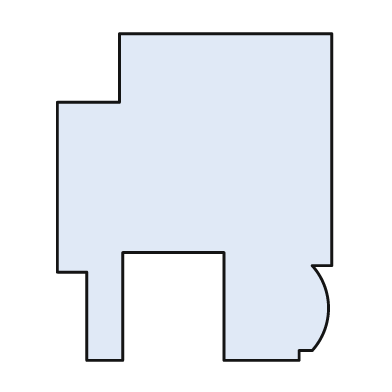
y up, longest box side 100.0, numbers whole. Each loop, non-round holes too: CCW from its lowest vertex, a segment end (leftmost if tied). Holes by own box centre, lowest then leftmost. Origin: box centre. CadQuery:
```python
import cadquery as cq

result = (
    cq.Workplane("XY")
    .moveTo(-33.0, -50.0)
    .lineTo(-22.0, -50.0)
    .lineTo(-22.0, -17.0)
    .lineTo(9.0, -17.0)
    .lineTo(9.0, -50.0)
    .lineTo(32.0, -50.0)
    .lineTo(32.0, -47.0)
    .lineTo(36.0, -47.0)
    .threePointArc((41.0, -34.0), (36.0, -21.0))
    .lineTo(42.0, -21.0)
    .lineTo(42.0, 50.0)
    .lineTo(-23.0, 50.0)
    .lineTo(-23.0, 29.0)
    .lineTo(-42.0, 29.0)
    .lineTo(-42.0, -23.0)
    .lineTo(-33.0, -23.0)
    .close()
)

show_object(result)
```